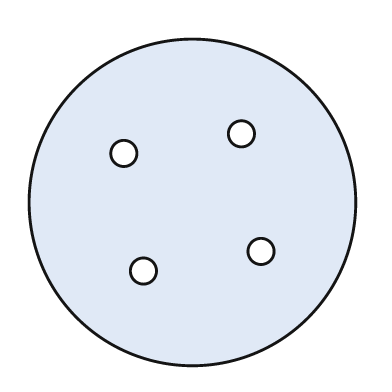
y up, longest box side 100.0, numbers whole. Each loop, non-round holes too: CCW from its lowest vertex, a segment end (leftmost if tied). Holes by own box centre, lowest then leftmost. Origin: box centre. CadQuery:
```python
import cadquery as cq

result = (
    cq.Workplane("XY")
    .moveTo(0.0, 0.0)
    .circle(50.0)
    .moveTo(-15.0, -21.0)
    .circle(4.0)
    .moveTo(21.0, -15.0)
    .circle(4.0)
    .moveTo(-21.0, 15.0)
    .circle(4.0)
    .moveTo(15.0, 21.0)
    .circle(4.0)
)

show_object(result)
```